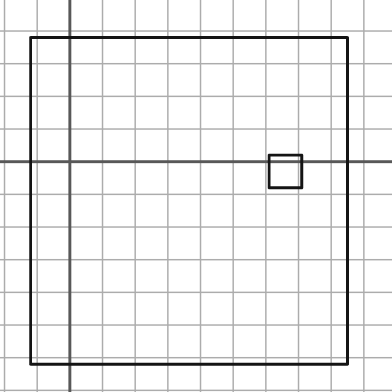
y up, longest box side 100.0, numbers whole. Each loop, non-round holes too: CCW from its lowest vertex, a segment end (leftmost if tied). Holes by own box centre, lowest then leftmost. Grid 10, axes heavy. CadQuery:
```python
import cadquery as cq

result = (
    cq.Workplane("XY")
    .moveTo(-12.0, -62.0)
    .lineTo(85.0, -62.0)
    .lineTo(85.0, 38.0)
    .lineTo(-12.0, 38.0)
    .close()
    .moveTo(61.0, -8.0)
    .lineTo(71.0, -8.0)
    .lineTo(71.0, 2.0)
    .lineTo(61.0, 2.0)
    .close()
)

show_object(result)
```